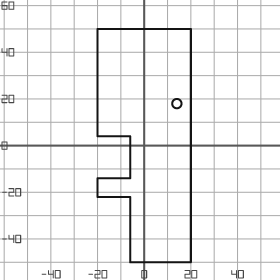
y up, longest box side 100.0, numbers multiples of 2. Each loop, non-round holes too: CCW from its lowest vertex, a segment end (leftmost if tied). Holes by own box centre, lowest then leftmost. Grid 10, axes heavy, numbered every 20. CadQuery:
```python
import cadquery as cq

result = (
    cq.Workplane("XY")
    .moveTo(-6.0, -50.0)
    .lineTo(20.0, -50.0)
    .lineTo(20.0, 50.0)
    .lineTo(-20.0, 50.0)
    .lineTo(-20.0, 4.0)
    .lineTo(-6.0, 4.0)
    .lineTo(-6.0, -14.0)
    .lineTo(-20.0, -14.0)
    .lineTo(-20.0, -22.0)
    .lineTo(-6.0, -22.0)
    .close()
    .moveTo(14.0, 18.0)
    .circle(2.0)
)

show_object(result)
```